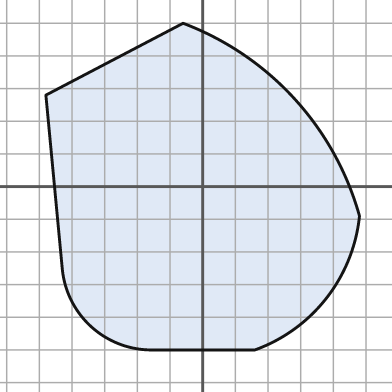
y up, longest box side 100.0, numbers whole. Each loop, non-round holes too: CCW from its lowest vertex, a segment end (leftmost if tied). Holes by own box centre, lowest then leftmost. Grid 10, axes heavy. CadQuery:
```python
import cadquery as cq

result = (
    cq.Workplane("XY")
    .moveTo(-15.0, -50.0)
    .lineTo(16.0, -50.0)
    .threePointArc((38.0, -34.0), (48.0, -9.0))
    .threePointArc((28.0, 27.0), (-6.0, 50.0))
    .lineTo(-48.0, 28.0)
    .lineTo(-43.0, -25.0)
    .threePointArc((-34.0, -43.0), (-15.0, -50.0))
    .close()
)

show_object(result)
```